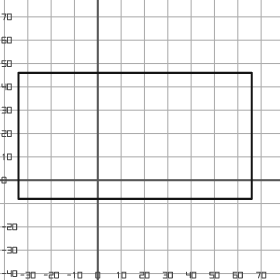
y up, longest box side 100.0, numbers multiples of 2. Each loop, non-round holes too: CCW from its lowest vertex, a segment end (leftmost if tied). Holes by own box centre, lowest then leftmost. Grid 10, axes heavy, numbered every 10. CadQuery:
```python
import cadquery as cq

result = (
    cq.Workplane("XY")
    .moveTo(-34.0, -8.0)
    .lineTo(66.0, -8.0)
    .lineTo(66.0, 46.0)
    .lineTo(-34.0, 46.0)
    .close()
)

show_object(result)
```